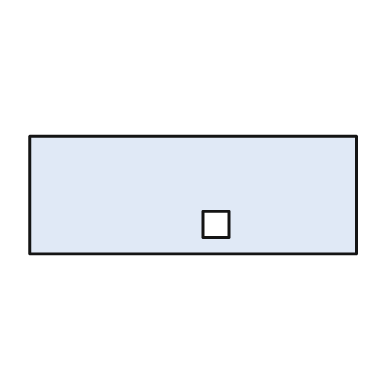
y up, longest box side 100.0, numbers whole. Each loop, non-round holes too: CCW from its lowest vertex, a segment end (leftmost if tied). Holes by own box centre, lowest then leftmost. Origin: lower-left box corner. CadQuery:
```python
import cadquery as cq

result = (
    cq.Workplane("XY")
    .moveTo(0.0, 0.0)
    .lineTo(100.0, 0.0)
    .lineTo(100.0, 36.0)
    .lineTo(0.0, 36.0)
    .close()
    .moveTo(53.0, 5.0)
    .lineTo(61.0, 5.0)
    .lineTo(61.0, 13.0)
    .lineTo(53.0, 13.0)
    .close()
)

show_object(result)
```